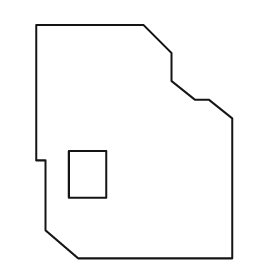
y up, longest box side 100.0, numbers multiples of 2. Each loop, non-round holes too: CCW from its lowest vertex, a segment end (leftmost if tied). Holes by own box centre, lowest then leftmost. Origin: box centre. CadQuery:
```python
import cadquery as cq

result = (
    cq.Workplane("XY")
    .moveTo(-24.0, -50.0)
    .lineTo(42.0, -50.0)
    .lineTo(42.0, 10.0)
    .lineTo(32.0, 18.0)
    .lineTo(26.0, 18.0)
    .lineTo(16.0, 26.0)
    .lineTo(16.0, 38.0)
    .lineTo(4.0, 50.0)
    .lineTo(-42.0, 50.0)
    .lineTo(-42.0, -8.0)
    .lineTo(-38.0, -8.0)
    .lineTo(-38.0, -38.0)
    .close()
    .moveTo(-28.0, -24.0)
    .lineTo(-12.0, -24.0)
    .lineTo(-12.0, -4.0)
    .lineTo(-28.0, -4.0)
    .close()
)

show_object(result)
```